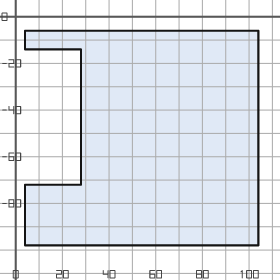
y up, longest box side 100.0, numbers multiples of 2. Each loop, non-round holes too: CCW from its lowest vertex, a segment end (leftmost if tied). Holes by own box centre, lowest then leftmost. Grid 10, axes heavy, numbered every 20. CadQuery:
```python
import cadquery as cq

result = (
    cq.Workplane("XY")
    .moveTo(4.0, -98.0)
    .lineTo(104.0, -98.0)
    .lineTo(104.0, -6.0)
    .lineTo(4.0, -6.0)
    .lineTo(4.0, -14.0)
    .lineTo(28.0, -14.0)
    .lineTo(28.0, -72.0)
    .lineTo(4.0, -72.0)
    .close()
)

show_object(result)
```